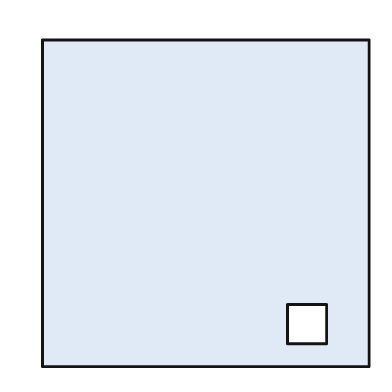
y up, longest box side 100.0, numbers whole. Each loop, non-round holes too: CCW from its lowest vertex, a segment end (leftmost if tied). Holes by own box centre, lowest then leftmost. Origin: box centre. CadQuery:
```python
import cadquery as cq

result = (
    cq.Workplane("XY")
    .moveTo(-50.0, -50.0)
    .lineTo(50.0, -50.0)
    .lineTo(50.0, 50.0)
    .lineTo(-50.0, 50.0)
    .close()
    .moveTo(25.0, -43.0)
    .lineTo(37.0, -43.0)
    .lineTo(37.0, -31.0)
    .lineTo(25.0, -31.0)
    .close()
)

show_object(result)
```